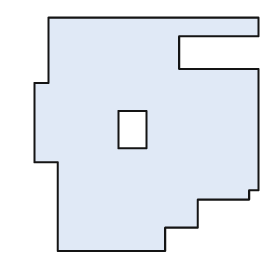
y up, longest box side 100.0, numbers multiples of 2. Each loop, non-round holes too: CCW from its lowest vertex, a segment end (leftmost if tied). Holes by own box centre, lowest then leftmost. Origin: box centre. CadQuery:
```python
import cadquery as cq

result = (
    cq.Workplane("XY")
    .moveTo(-38.0, -50.0)
    .lineTo(8.0, -50.0)
    .lineTo(8.0, -40.0)
    .lineTo(22.0, -40.0)
    .lineTo(22.0, -28.0)
    .lineTo(44.0, -28.0)
    .lineTo(44.0, -24.0)
    .lineTo(48.0, -24.0)
    .lineTo(48.0, 28.0)
    .lineTo(14.0, 28.0)
    .lineTo(14.0, 42.0)
    .lineTo(48.0, 42.0)
    .lineTo(48.0, 50.0)
    .lineTo(-42.0, 50.0)
    .lineTo(-42.0, 22.0)
    .lineTo(-48.0, 22.0)
    .lineTo(-48.0, -12.0)
    .lineTo(-38.0, -12.0)
    .close()
    .moveTo(-12.0, -6.0)
    .lineTo(0.0, -6.0)
    .lineTo(0.0, 10.0)
    .lineTo(-12.0, 10.0)
    .close()
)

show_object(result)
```